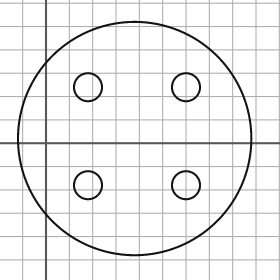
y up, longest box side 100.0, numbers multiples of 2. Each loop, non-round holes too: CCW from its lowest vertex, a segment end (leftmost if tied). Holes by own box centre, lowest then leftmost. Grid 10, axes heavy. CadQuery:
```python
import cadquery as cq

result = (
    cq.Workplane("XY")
    .moveTo(38.0, 2.0)
    .circle(50.0)
    .moveTo(18.0, -18.0)
    .circle(6.0)
    .moveTo(60.0, -18.0)
    .circle(6.0)
    .moveTo(18.0, 24.0)
    .circle(6.0)
    .moveTo(60.0, 24.0)
    .circle(6.0)
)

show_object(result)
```